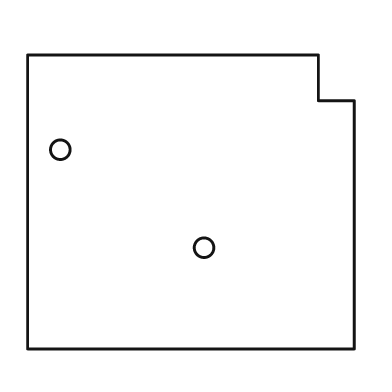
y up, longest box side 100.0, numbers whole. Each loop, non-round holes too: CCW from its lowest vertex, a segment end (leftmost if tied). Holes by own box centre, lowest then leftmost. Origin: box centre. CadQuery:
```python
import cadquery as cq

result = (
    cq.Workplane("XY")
    .moveTo(-50.0, -45.0)
    .lineTo(50.0, -45.0)
    .lineTo(50.0, 31.0)
    .lineTo(39.0, 31.0)
    .lineTo(39.0, 45.0)
    .lineTo(-50.0, 45.0)
    .close()
    .moveTo(4.0, -14.0)
    .circle(3.0)
    .moveTo(-40.0, 16.0)
    .circle(3.0)
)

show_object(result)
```